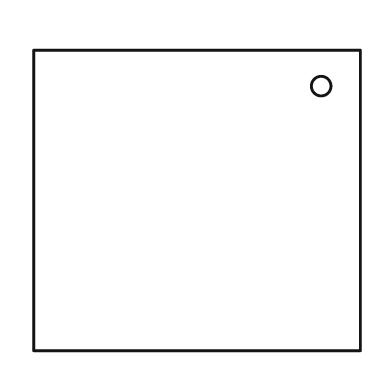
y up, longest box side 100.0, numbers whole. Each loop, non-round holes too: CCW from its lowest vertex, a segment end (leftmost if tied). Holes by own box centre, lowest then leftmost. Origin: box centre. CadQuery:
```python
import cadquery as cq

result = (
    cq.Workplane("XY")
    .moveTo(-50.0, -46.0)
    .lineTo(50.0, -46.0)
    .lineTo(50.0, 46.0)
    .lineTo(-50.0, 46.0)
    .close()
    .moveTo(38.0, 35.0)
    .circle(3.0)
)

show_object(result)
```